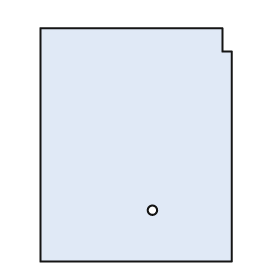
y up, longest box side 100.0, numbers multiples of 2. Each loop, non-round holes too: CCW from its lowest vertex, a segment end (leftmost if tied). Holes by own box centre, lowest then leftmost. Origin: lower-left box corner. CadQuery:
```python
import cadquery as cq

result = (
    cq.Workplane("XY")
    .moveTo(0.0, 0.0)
    .lineTo(82.0, 0.0)
    .lineTo(82.0, 90.0)
    .lineTo(78.0, 90.0)
    .lineTo(78.0, 100.0)
    .lineTo(0.0, 100.0)
    .close()
    .moveTo(48.0, 22.0)
    .circle(2.0)
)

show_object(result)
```